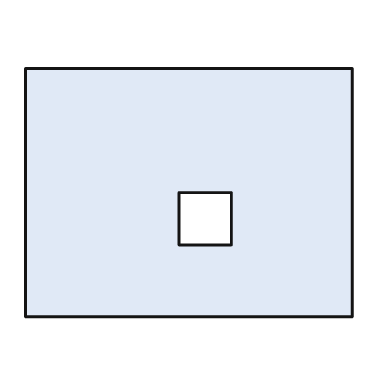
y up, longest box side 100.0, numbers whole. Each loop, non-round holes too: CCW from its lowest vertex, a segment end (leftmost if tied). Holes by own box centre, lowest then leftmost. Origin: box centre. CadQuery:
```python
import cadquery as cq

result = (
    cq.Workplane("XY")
    .moveTo(-50.0, -38.0)
    .lineTo(50.0, -38.0)
    .lineTo(50.0, 38.0)
    .lineTo(-50.0, 38.0)
    .close()
    .moveTo(-3.0, -16.0)
    .lineTo(13.0, -16.0)
    .lineTo(13.0, 0.0)
    .lineTo(-3.0, 0.0)
    .close()
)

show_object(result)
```